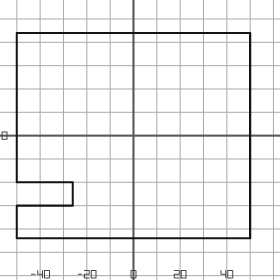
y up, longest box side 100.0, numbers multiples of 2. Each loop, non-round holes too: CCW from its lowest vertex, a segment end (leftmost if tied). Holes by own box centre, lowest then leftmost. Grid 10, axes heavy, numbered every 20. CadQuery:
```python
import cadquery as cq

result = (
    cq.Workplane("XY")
    .moveTo(-50.0, -44.0)
    .lineTo(50.0, -44.0)
    .lineTo(50.0, 44.0)
    .lineTo(-50.0, 44.0)
    .lineTo(-50.0, -20.0)
    .lineTo(-26.0, -20.0)
    .lineTo(-26.0, -30.0)
    .lineTo(-50.0, -30.0)
    .close()
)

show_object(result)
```